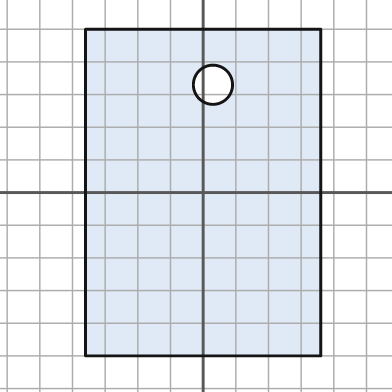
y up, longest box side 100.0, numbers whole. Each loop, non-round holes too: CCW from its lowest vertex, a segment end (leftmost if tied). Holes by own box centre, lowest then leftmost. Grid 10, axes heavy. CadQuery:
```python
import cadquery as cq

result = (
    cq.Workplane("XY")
    .moveTo(-36.0, -50.0)
    .lineTo(36.0, -50.0)
    .lineTo(36.0, 50.0)
    .lineTo(-36.0, 50.0)
    .close()
    .moveTo(3.0, 33.0)
    .circle(6.0)
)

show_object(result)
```